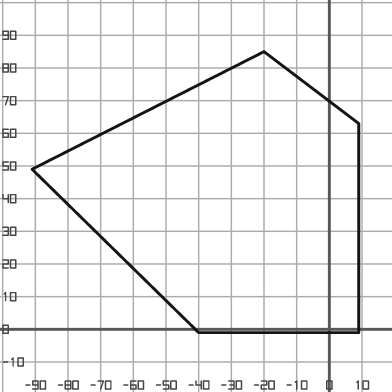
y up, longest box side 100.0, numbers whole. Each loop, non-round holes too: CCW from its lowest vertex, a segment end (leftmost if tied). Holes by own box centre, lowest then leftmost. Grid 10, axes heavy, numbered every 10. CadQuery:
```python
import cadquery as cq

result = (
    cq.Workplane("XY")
    .moveTo(-40.0, -1.0)
    .lineTo(9.0, -1.0)
    .lineTo(9.0, 63.0)
    .lineTo(-20.0, 85.0)
    .lineTo(-91.0, 49.0)
    .close()
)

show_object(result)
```